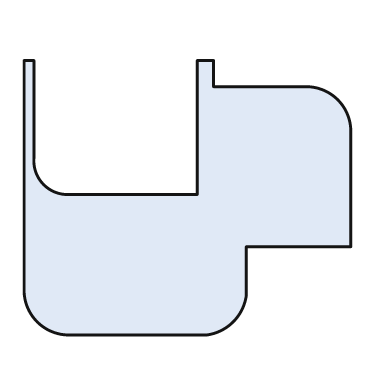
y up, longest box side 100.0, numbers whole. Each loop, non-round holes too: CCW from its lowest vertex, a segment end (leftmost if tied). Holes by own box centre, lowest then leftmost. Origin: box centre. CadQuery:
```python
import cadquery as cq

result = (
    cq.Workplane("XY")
    .moveTo(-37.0, -42.0)
    .lineTo(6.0, -42.0)
    .threePointArc((14.0, -38.0), (18.0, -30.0))
    .lineTo(18.0, -15.0)
    .lineTo(50.0, -15.0)
    .lineTo(50.0, 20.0)
    .threePointArc((46.0, 30.0), (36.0, 34.0))
    .lineTo(8.0, 34.0)
    .lineTo(8.0, 42.0)
    .lineTo(3.0, 42.0)
    .lineTo(3.0, 1.0)
    .lineTo(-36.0, 1.0)
    .threePointArc((-44.0, 4.0), (-47.0, 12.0))
    .lineTo(-47.0, 42.0)
    .lineTo(-50.0, 42.0)
    .lineTo(-50.0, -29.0)
    .threePointArc((-46.0, -38.0), (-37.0, -42.0))
    .close()
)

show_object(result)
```